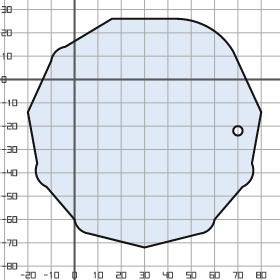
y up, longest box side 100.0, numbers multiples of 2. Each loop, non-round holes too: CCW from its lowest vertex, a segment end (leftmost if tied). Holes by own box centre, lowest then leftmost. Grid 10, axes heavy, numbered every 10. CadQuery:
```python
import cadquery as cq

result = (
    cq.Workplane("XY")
    .moveTo(30.0, -72.0)
    .lineTo(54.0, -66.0)
    .threePointArc((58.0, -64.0), (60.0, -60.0))
    .lineTo(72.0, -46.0)
    .threePointArc((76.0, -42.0), (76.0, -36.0))
    .lineTo(80.0, -14.0)
    .lineTo(68.0, 12.0)
    .threePointArc((58.0, 22.0), (44.0, 26.0))
    .lineTo(16.0, 26.0)
    .lineTo(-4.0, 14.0)
    .threePointArc((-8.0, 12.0), (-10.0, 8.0))
    .lineTo(-20.0, -14.0)
    .lineTo(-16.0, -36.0)
    .threePointArc((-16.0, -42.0), (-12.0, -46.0))
    .lineTo(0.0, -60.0)
    .threePointArc((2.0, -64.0), (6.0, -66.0))
    .close()
    .moveTo(70.0, -22.0)
    .circle(2.0)
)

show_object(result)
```